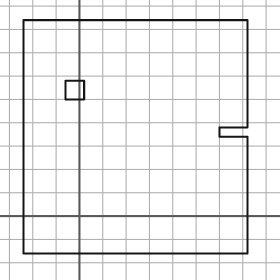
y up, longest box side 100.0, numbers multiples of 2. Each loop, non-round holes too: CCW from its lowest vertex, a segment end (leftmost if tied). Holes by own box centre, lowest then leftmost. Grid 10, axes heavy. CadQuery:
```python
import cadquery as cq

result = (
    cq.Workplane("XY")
    .moveTo(-24.0, -16.0)
    .lineTo(72.0, -16.0)
    .lineTo(72.0, 34.0)
    .lineTo(60.0, 34.0)
    .lineTo(60.0, 38.0)
    .lineTo(72.0, 38.0)
    .lineTo(72.0, 84.0)
    .lineTo(-24.0, 84.0)
    .close()
    .moveTo(-6.0, 50.0)
    .lineTo(2.0, 50.0)
    .lineTo(2.0, 58.0)
    .lineTo(-6.0, 58.0)
    .close()
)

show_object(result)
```